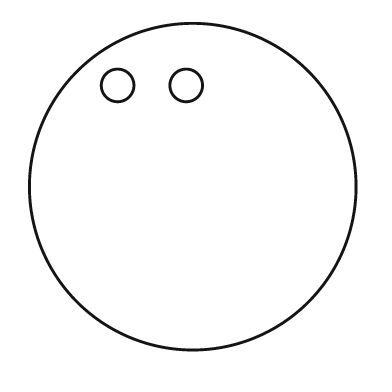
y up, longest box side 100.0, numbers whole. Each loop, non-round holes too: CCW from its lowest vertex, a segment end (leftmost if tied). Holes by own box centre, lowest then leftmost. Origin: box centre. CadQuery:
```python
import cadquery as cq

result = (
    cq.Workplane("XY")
    .moveTo(0.0, 0.0)
    .circle(50.0)
    .moveTo(-23.0, 31.0)
    .circle(5.0)
    .moveTo(-2.0, 31.0)
    .circle(5.0)
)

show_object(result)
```